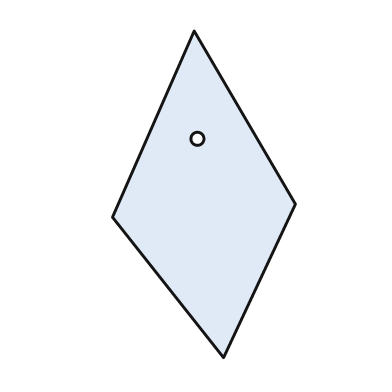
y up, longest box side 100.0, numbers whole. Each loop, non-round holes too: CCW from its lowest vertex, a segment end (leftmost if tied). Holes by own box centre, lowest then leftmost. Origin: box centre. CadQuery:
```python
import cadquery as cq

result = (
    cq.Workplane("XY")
    .moveTo(6.0, -50.0)
    .lineTo(28.0, -3.0)
    .lineTo(-3.0, 50.0)
    .lineTo(-28.0, -7.0)
    .close()
    .moveTo(-2.0, 17.0)
    .circle(2.0)
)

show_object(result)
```